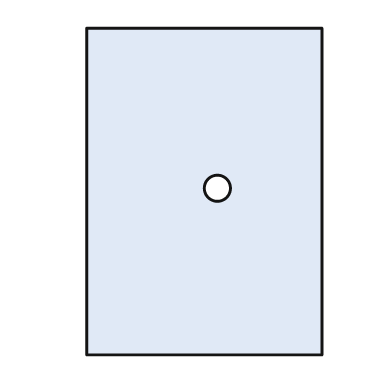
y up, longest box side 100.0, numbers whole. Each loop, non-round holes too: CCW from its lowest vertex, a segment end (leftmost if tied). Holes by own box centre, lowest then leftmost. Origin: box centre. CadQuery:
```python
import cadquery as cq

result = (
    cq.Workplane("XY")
    .moveTo(-36.0, -50.0)
    .lineTo(36.0, -50.0)
    .lineTo(36.0, 50.0)
    .lineTo(-36.0, 50.0)
    .close()
    .moveTo(4.0, 1.0)
    .circle(4.0)
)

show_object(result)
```